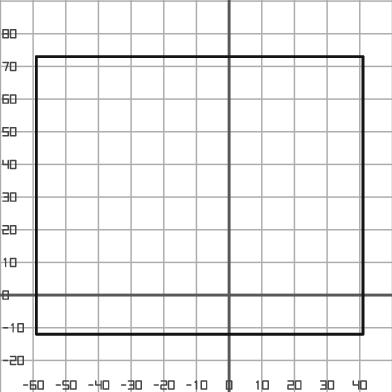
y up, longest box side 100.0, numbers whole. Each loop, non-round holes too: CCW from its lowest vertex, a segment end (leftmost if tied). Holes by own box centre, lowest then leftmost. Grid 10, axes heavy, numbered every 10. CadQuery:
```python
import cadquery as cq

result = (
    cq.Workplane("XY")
    .moveTo(-59.0, -12.0)
    .lineTo(41.0, -12.0)
    .lineTo(41.0, 73.0)
    .lineTo(-59.0, 73.0)
    .close()
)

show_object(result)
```